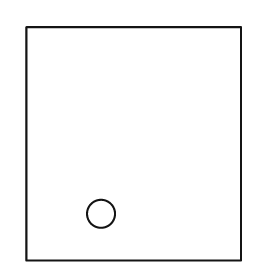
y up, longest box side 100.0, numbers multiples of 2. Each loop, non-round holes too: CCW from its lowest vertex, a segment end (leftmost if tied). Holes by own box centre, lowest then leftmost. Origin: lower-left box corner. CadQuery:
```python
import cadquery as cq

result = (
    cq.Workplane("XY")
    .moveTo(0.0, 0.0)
    .lineTo(92.0, 0.0)
    .lineTo(92.0, 100.0)
    .lineTo(0.0, 100.0)
    .close()
    .moveTo(32.0, 20.0)
    .circle(6.0)
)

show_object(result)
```